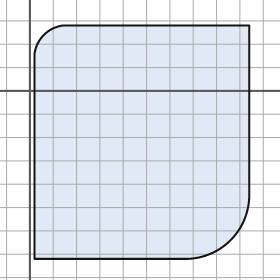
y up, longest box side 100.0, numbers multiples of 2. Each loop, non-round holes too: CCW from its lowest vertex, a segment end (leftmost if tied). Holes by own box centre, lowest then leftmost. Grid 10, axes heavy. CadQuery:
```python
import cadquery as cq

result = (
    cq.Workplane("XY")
    .moveTo(2.0, -72.0)
    .lineTo(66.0, -72.0)
    .threePointArc((86.0, -64.0), (94.0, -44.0))
    .lineTo(94.0, 28.0)
    .lineTo(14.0, 28.0)
    .threePointArc((6.0, 24.0), (2.0, 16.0))
    .close()
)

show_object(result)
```